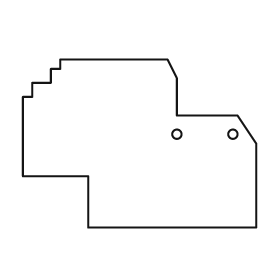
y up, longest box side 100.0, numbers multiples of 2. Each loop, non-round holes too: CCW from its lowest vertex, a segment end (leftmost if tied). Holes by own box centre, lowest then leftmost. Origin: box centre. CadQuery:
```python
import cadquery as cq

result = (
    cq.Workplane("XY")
    .moveTo(-22.0, -36.0)
    .lineTo(50.0, -36.0)
    .lineTo(50.0, 0.0)
    .lineTo(42.0, 12.0)
    .lineTo(16.0, 12.0)
    .lineTo(16.0, 28.0)
    .lineTo(12.0, 36.0)
    .lineTo(-34.0, 36.0)
    .lineTo(-34.0, 32.0)
    .lineTo(-38.0, 32.0)
    .lineTo(-38.0, 26.0)
    .lineTo(-46.0, 26.0)
    .lineTo(-46.0, 20.0)
    .lineTo(-50.0, 20.0)
    .lineTo(-50.0, -14.0)
    .lineTo(-22.0, -14.0)
    .close()
    .moveTo(16.0, 4.0)
    .circle(2.0)
    .moveTo(40.0, 4.0)
    .circle(2.0)
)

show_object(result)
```